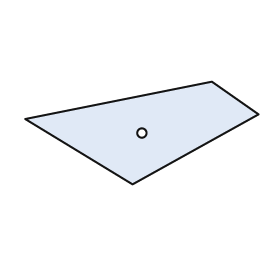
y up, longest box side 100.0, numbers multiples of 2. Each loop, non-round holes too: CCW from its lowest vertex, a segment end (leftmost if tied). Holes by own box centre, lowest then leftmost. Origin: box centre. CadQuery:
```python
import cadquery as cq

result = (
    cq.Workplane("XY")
    .moveTo(-4.0, -22.0)
    .lineTo(50.0, 8.0)
    .lineTo(30.0, 22.0)
    .lineTo(-50.0, 6.0)
    .close()
    .moveTo(0.0, 0.0)
    .circle(2.0)
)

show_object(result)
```